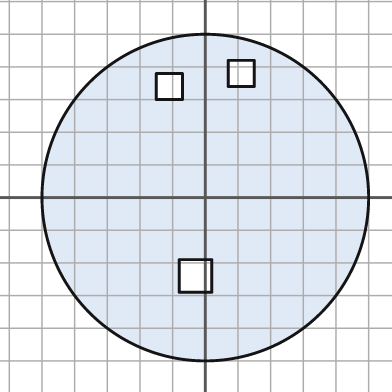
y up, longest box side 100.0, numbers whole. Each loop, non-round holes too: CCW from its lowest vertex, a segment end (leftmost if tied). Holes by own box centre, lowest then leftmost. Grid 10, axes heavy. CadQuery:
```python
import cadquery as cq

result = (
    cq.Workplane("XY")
    .moveTo(0.0, 0.0)
    .circle(50.0)
    .moveTo(-8.0, -29.0)
    .lineTo(2.0, -29.0)
    .lineTo(2.0, -19.0)
    .lineTo(-8.0, -19.0)
    .close()
    .moveTo(-15.0, 30.0)
    .lineTo(-7.0, 30.0)
    .lineTo(-7.0, 38.0)
    .lineTo(-15.0, 38.0)
    .close()
    .moveTo(7.0, 34.0)
    .lineTo(15.0, 34.0)
    .lineTo(15.0, 42.0)
    .lineTo(7.0, 42.0)
    .close()
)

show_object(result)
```